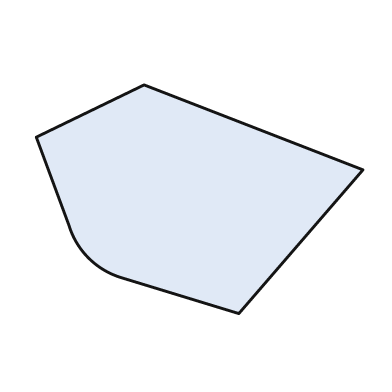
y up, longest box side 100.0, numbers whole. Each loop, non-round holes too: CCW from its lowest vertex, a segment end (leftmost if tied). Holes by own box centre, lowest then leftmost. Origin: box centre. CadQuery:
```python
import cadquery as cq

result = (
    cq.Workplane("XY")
    .moveTo(12.0, -35.0)
    .lineTo(50.0, 9.0)
    .lineTo(-17.0, 35.0)
    .lineTo(-50.0, 19.0)
    .lineTo(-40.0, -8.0)
    .threePointArc((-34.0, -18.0), (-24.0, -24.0))
    .close()
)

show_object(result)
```